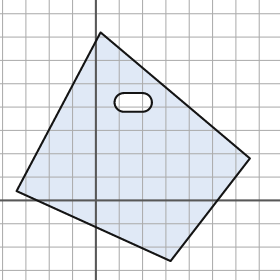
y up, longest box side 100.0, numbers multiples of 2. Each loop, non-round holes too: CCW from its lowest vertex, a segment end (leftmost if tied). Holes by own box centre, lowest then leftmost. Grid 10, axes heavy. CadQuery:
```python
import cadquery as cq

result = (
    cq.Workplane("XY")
    .moveTo(32.0, -26.0)
    .lineTo(66.0, 18.0)
    .lineTo(2.0, 72.0)
    .lineTo(-34.0, 4.0)
    .close()
    .moveTo(12.0, 38.0)
    .lineTo(20.0, 38.0)
    .threePointArc((24.0, 42.0), (20.0, 46.0))
    .lineTo(12.0, 46.0)
    .threePointArc((8.0, 42.0), (12.0, 38.0))
    .close()
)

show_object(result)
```